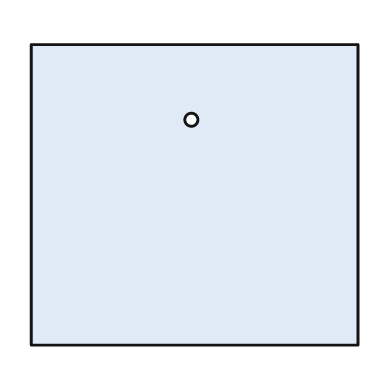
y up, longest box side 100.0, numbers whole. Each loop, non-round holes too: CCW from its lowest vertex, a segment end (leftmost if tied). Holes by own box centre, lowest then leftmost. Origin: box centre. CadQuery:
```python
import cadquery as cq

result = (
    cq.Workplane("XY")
    .moveTo(-50.0, -46.0)
    .lineTo(50.0, -46.0)
    .lineTo(50.0, 46.0)
    .lineTo(-50.0, 46.0)
    .close()
    .moveTo(-1.0, 23.0)
    .circle(2.0)
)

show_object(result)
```